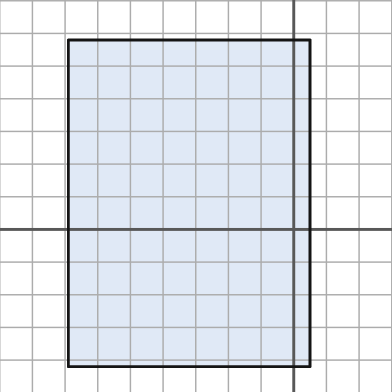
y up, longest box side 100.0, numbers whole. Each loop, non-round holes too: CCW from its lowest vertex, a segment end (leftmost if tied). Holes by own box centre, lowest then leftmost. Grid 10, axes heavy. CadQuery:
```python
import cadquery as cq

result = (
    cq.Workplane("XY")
    .moveTo(-69.0, -42.0)
    .lineTo(5.0, -42.0)
    .lineTo(5.0, 58.0)
    .lineTo(-69.0, 58.0)
    .close()
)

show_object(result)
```